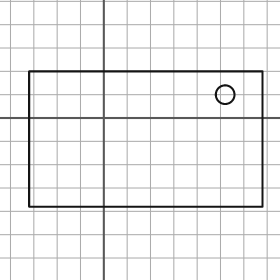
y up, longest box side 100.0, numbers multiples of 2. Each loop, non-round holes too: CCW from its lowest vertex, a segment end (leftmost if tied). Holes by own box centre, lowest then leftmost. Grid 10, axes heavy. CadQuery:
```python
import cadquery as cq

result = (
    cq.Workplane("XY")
    .moveTo(-32.0, -38.0)
    .lineTo(68.0, -38.0)
    .lineTo(68.0, 20.0)
    .lineTo(-32.0, 20.0)
    .close()
    .moveTo(52.0, 10.0)
    .circle(4.0)
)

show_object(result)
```